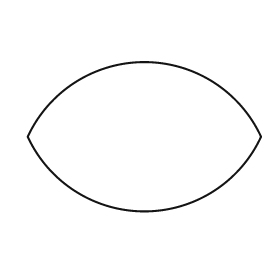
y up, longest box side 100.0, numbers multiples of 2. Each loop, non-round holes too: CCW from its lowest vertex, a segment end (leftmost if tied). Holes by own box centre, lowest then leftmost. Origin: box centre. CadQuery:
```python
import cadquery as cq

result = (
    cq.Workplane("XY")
    .moveTo(-50.0, 0.0)
    .threePointArc((0.0, -32.0), (50.0, 0.0))
    .threePointArc((0.0, 32.0), (-50.0, 0.0))
    .close()
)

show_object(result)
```